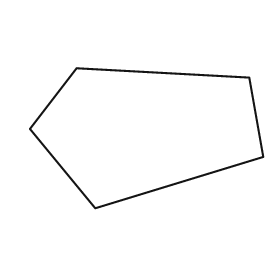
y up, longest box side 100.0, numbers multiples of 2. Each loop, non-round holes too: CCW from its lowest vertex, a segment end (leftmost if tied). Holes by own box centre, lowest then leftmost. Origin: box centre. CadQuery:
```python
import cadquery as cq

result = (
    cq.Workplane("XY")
    .moveTo(-22.0, -30.0)
    .lineTo(50.0, -8.0)
    .lineTo(44.0, 26.0)
    .lineTo(-30.0, 30.0)
    .lineTo(-50.0, 4.0)
    .close()
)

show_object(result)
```